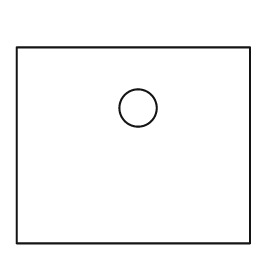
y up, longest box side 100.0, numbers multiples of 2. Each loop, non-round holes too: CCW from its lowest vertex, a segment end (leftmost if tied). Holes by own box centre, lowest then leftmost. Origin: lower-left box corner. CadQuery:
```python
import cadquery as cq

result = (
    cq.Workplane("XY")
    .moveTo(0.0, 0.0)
    .lineTo(100.0, 0.0)
    .lineTo(100.0, 84.0)
    .lineTo(0.0, 84.0)
    .close()
    .moveTo(52.0, 58.0)
    .circle(8.0)
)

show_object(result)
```